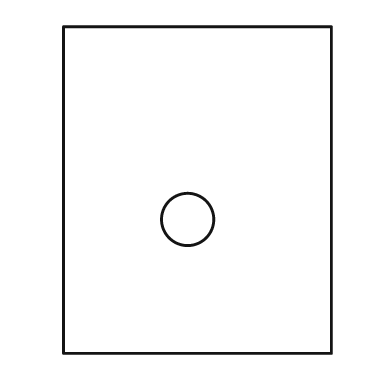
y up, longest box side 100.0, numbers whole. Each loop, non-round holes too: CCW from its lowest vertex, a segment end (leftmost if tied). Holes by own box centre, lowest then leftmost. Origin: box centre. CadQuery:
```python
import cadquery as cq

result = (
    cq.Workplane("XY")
    .moveTo(-41.0, -50.0)
    .lineTo(41.0, -50.0)
    .lineTo(41.0, 50.0)
    .lineTo(-41.0, 50.0)
    .close()
    .moveTo(-3.0, -9.0)
    .circle(8.0)
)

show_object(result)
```